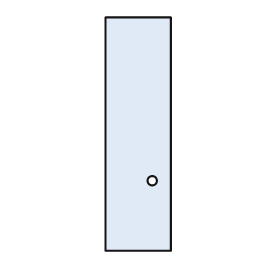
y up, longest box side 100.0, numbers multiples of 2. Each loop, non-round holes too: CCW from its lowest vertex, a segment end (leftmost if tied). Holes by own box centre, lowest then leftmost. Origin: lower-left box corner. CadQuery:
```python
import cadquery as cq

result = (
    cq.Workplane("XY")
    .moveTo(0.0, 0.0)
    .lineTo(28.0, 0.0)
    .lineTo(28.0, 100.0)
    .lineTo(0.0, 100.0)
    .close()
    .moveTo(20.0, 30.0)
    .circle(2.0)
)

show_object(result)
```